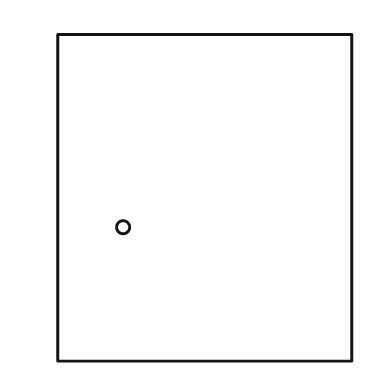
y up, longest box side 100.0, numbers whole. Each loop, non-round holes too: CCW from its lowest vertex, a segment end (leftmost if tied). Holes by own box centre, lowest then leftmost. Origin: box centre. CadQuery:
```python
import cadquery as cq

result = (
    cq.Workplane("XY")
    .moveTo(-45.0, -50.0)
    .lineTo(45.0, -50.0)
    .lineTo(45.0, 50.0)
    .lineTo(-45.0, 50.0)
    .close()
    .moveTo(-25.0, -9.0)
    .circle(2.0)
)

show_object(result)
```